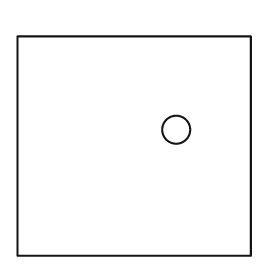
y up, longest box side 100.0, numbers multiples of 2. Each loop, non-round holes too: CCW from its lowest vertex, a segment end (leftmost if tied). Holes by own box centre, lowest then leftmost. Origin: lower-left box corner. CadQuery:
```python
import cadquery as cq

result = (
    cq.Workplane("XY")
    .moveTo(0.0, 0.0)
    .lineTo(100.0, 0.0)
    .lineTo(100.0, 94.0)
    .lineTo(0.0, 94.0)
    .close()
    .moveTo(68.0, 54.0)
    .circle(6.0)
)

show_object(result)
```